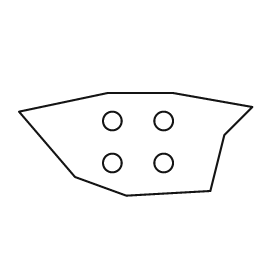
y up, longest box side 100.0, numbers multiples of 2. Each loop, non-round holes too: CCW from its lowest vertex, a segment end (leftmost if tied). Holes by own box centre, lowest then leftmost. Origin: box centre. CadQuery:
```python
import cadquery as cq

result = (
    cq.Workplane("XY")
    .moveTo(-4.0, -22.0)
    .lineTo(32.0, -20.0)
    .lineTo(38.0, 4.0)
    .lineTo(50.0, 16.0)
    .lineTo(16.0, 22.0)
    .lineTo(-12.0, 22.0)
    .lineTo(-50.0, 14.0)
    .lineTo(-26.0, -14.0)
    .close()
    .moveTo(-10.0, -8.0)
    .circle(4.0)
    .moveTo(12.0, -8.0)
    .circle(4.0)
    .moveTo(-10.0, 10.0)
    .circle(4.0)
    .moveTo(12.0, 10.0)
    .circle(4.0)
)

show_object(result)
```